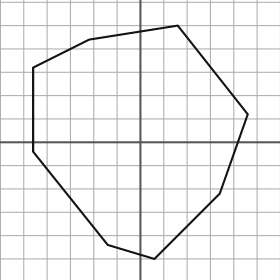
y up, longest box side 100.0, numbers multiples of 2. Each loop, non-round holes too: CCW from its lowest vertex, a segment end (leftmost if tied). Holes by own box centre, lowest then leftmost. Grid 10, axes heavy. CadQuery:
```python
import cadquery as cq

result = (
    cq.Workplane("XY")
    .moveTo(6.0, -50.0)
    .lineTo(34.0, -22.0)
    .lineTo(46.0, 12.0)
    .lineTo(16.0, 50.0)
    .lineTo(-22.0, 44.0)
    .lineTo(-46.0, 32.0)
    .lineTo(-46.0, -4.0)
    .lineTo(-14.0, -44.0)
    .close()
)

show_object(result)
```